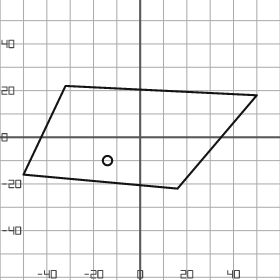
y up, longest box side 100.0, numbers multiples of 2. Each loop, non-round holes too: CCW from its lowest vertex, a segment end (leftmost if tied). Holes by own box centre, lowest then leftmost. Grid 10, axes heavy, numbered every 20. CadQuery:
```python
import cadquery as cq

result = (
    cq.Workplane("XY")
    .moveTo(16.0, -22.0)
    .lineTo(50.0, 18.0)
    .lineTo(-32.0, 22.0)
    .lineTo(-50.0, -16.0)
    .close()
    .moveTo(-14.0, -10.0)
    .circle(2.0)
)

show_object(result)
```